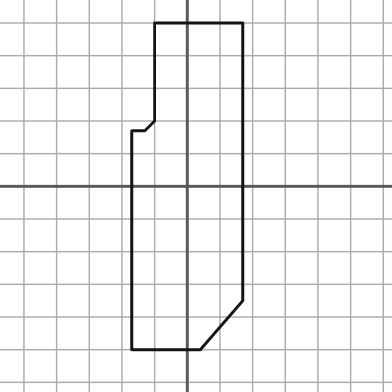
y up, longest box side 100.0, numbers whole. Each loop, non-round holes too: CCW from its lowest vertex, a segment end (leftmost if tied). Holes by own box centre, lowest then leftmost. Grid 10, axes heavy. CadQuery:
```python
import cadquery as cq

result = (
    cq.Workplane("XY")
    .moveTo(-17.0, -50.0)
    .lineTo(4.0, -50.0)
    .lineTo(17.0, -35.0)
    .lineTo(17.0, 50.0)
    .lineTo(-10.0, 50.0)
    .lineTo(-10.0, 20.0)
    .lineTo(-13.0, 17.0)
    .lineTo(-17.0, 17.0)
    .close()
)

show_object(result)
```